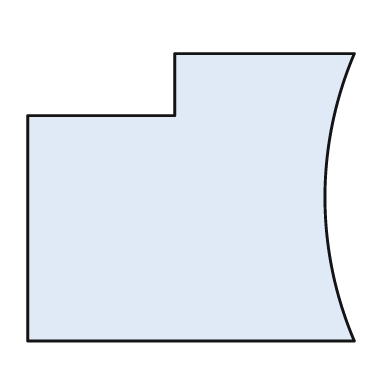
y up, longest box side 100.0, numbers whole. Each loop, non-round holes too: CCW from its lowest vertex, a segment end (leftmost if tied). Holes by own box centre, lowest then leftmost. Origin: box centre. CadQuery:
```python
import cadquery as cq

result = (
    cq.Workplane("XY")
    .moveTo(-50.0, -44.0)
    .lineTo(50.0, -44.0)
    .threePointArc((41.0, 0.0), (50.0, 44.0))
    .lineTo(-5.0, 44.0)
    .lineTo(-5.0, 25.0)
    .lineTo(-50.0, 25.0)
    .close()
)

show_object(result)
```